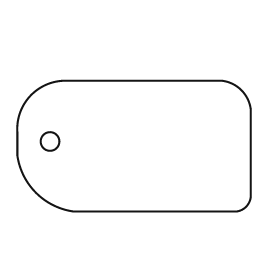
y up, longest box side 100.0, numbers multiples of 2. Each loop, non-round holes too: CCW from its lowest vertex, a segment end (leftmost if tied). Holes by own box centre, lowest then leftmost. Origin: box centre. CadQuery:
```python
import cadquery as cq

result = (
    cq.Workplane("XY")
    .moveTo(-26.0, -28.0)
    .lineTo(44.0, -28.0)
    .threePointArc((48.0, -26.0), (50.0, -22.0))
    .lineTo(50.0, 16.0)
    .threePointArc((46.0, 24.0), (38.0, 28.0))
    .lineTo(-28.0, 28.0)
    .threePointArc((-44.0, 22.0), (-50.0, 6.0))
    .lineTo(-50.0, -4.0)
    .threePointArc((-42.0, -20.0), (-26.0, -28.0))
    .close()
    .moveTo(-36.0, 2.0)
    .circle(4.0)
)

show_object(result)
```